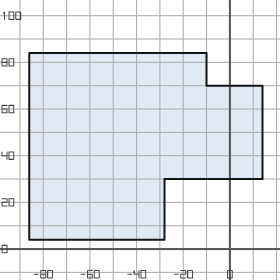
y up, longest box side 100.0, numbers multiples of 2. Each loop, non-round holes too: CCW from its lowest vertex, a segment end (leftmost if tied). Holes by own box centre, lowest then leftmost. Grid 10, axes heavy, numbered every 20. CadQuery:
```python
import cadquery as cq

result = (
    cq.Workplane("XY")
    .moveTo(-86.0, 4.0)
    .lineTo(-28.0, 4.0)
    .lineTo(-28.0, 30.0)
    .lineTo(14.0, 30.0)
    .lineTo(14.0, 70.0)
    .lineTo(-10.0, 70.0)
    .lineTo(-10.0, 84.0)
    .lineTo(-86.0, 84.0)
    .close()
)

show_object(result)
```